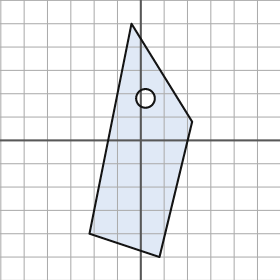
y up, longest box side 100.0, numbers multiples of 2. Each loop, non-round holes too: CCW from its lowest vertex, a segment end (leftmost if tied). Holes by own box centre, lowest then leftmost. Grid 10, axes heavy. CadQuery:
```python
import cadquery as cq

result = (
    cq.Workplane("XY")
    .moveTo(8.0, -50.0)
    .lineTo(22.0, 8.0)
    .lineTo(-4.0, 50.0)
    .lineTo(-22.0, -40.0)
    .close()
    .moveTo(2.0, 18.0)
    .circle(4.0)
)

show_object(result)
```